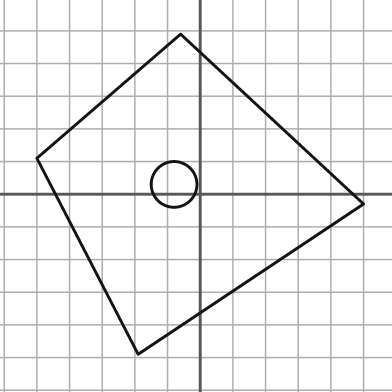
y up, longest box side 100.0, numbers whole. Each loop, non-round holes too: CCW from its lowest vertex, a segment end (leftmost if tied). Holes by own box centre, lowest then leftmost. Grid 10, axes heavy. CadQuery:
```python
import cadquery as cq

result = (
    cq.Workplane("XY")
    .moveTo(-19.0, -49.0)
    .lineTo(50.0, -3.0)
    .lineTo(-6.0, 49.0)
    .lineTo(-50.0, 11.0)
    .close()
    .moveTo(-8.0, 3.0)
    .circle(7.0)
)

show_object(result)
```